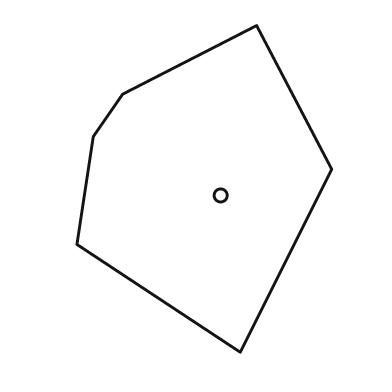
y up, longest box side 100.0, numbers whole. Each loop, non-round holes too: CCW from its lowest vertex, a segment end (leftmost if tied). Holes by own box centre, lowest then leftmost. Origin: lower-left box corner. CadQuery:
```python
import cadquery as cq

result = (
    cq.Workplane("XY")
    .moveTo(50.0, 0.0)
    .lineTo(78.0, 56.0)
    .lineTo(55.0, 100.0)
    .lineTo(14.0, 79.0)
    .lineTo(5.0, 66.0)
    .lineTo(0.0, 33.0)
    .close()
    .moveTo(44.0, 48.0)
    .circle(2.0)
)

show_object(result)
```